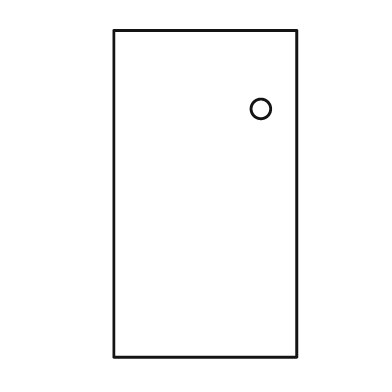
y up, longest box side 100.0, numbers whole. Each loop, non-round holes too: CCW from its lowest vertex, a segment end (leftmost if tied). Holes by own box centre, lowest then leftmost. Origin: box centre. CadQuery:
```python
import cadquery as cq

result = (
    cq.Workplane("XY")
    .moveTo(-28.0, -50.0)
    .lineTo(28.0, -50.0)
    .lineTo(28.0, 50.0)
    .lineTo(-28.0, 50.0)
    .close()
    .moveTo(17.0, 26.0)
    .circle(3.0)
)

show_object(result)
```